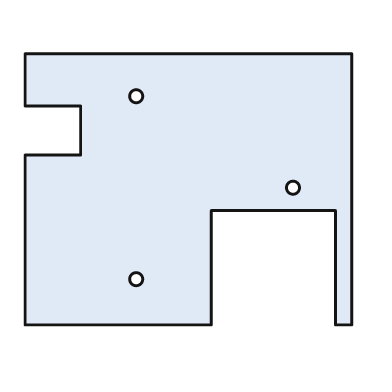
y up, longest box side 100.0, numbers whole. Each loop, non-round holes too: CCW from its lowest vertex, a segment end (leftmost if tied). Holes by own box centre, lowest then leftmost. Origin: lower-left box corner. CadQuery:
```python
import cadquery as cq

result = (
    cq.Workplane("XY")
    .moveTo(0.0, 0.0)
    .lineTo(57.0, 0.0)
    .lineTo(57.0, 35.0)
    .lineTo(95.0, 35.0)
    .lineTo(95.0, 0.0)
    .lineTo(100.0, 0.0)
    .lineTo(100.0, 83.0)
    .lineTo(0.0, 83.0)
    .lineTo(0.0, 67.0)
    .lineTo(17.0, 67.0)
    .lineTo(17.0, 52.0)
    .lineTo(0.0, 52.0)
    .close()
    .moveTo(34.0, 14.0)
    .circle(2.0)
    .moveTo(82.0, 42.0)
    .circle(2.0)
    .moveTo(34.0, 70.0)
    .circle(2.0)
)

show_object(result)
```